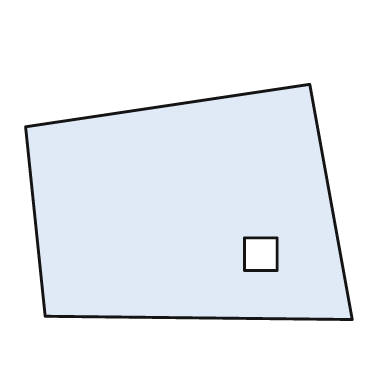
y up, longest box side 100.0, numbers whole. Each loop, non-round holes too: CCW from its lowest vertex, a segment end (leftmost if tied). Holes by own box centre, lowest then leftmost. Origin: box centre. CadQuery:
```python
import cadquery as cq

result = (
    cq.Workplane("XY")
    .moveTo(50.0, -36.0)
    .lineTo(37.0, 36.0)
    .lineTo(-50.0, 23.0)
    .lineTo(-44.0, -35.0)
    .close()
    .moveTo(17.0, -21.0)
    .lineTo(27.0, -21.0)
    .lineTo(27.0, -11.0)
    .lineTo(17.0, -11.0)
    .close()
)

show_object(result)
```